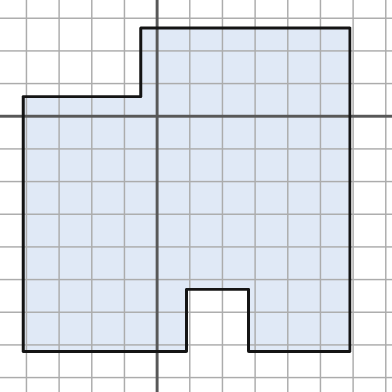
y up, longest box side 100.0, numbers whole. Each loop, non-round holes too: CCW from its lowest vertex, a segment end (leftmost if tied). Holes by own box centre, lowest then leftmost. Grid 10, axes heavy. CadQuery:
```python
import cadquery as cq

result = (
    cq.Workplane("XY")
    .moveTo(-41.0, -72.0)
    .lineTo(9.0, -72.0)
    .lineTo(9.0, -53.0)
    .lineTo(28.0, -53.0)
    .lineTo(28.0, -72.0)
    .lineTo(59.0, -72.0)
    .lineTo(59.0, 27.0)
    .lineTo(-5.0, 27.0)
    .lineTo(-5.0, 6.0)
    .lineTo(-41.0, 6.0)
    .close()
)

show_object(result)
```